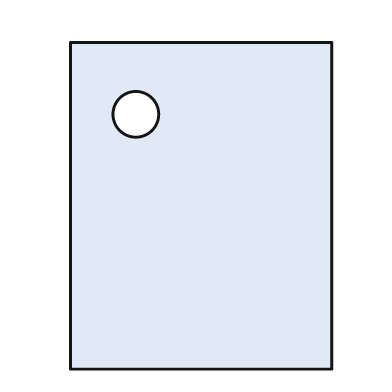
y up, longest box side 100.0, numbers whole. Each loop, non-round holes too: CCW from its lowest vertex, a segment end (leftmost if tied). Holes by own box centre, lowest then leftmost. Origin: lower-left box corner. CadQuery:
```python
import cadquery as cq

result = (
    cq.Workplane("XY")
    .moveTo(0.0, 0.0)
    .lineTo(80.0, 0.0)
    .lineTo(80.0, 100.0)
    .lineTo(0.0, 100.0)
    .close()
    .moveTo(20.0, 78.0)
    .circle(7.0)
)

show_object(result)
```